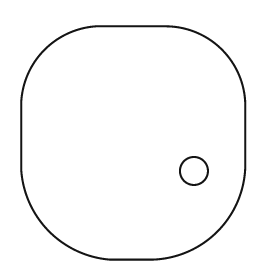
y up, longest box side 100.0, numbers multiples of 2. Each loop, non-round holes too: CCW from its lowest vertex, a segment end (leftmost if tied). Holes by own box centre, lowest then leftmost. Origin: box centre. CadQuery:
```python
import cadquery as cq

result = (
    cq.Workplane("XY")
    .moveTo(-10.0, -50.0)
    .lineTo(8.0, -50.0)
    .threePointArc((36.0, -38.0), (48.0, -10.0))
    .lineTo(48.0, 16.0)
    .threePointArc((38.0, 40.0), (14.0, 50.0))
    .lineTo(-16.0, 50.0)
    .threePointArc((-38.0, 40.0), (-48.0, 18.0))
    .lineTo(-48.0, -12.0)
    .threePointArc((-36.0, -38.0), (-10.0, -50.0))
    .close()
    .moveTo(26.0, -12.0)
    .circle(6.0)
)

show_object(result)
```